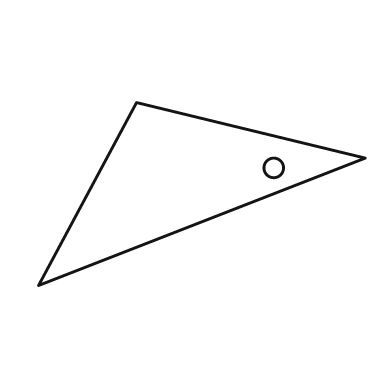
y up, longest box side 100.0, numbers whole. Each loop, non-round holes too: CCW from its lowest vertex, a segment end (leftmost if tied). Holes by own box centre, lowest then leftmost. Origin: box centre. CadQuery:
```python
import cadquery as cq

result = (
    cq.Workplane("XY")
    .moveTo(-50.0, -28.0)
    .lineTo(50.0, 11.0)
    .lineTo(-20.0, 28.0)
    .close()
    .moveTo(22.0, 8.0)
    .circle(3.0)
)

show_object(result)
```